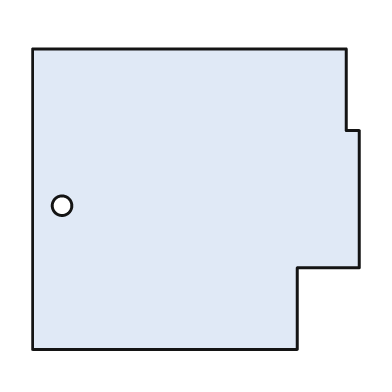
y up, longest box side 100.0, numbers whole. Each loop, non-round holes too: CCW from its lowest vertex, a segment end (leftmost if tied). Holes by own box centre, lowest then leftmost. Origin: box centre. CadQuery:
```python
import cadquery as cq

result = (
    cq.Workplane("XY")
    .moveTo(-50.0, -46.0)
    .lineTo(31.0, -46.0)
    .lineTo(31.0, -21.0)
    .lineTo(50.0, -21.0)
    .lineTo(50.0, 21.0)
    .lineTo(46.0, 21.0)
    .lineTo(46.0, 46.0)
    .lineTo(-50.0, 46.0)
    .close()
    .moveTo(-41.0, -2.0)
    .circle(3.0)
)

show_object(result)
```